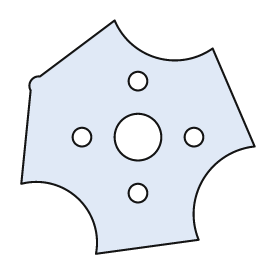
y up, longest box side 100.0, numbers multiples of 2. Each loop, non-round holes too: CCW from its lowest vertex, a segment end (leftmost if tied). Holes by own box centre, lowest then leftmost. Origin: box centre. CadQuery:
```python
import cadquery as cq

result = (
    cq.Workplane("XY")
    .moveTo(-18.0, -50.0)
    .lineTo(26.0, -44.0)
    .threePointArc((28.0, -18.0), (50.0, -4.0))
    .lineTo(32.0, 38.0)
    .threePointArc((8.0, 34.0), (-10.0, 50.0))
    .lineTo(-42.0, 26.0)
    .threePointArc((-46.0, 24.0), (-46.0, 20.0))
    .lineTo(-50.0, -20.0)
    .threePointArc((-26.0, -26.0), (-18.0, -50.0))
    .close()
    .moveTo(0.0, -24.0)
    .circle(4.0)
    .moveTo(-24.0, 0.0)
    .circle(4.0)
    .moveTo(0.0, 0.0)
    .circle(10.0)
    .moveTo(24.0, 0.0)
    .circle(4.0)
    .moveTo(0.0, 24.0)
    .circle(4.0)
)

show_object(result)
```